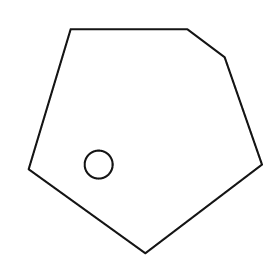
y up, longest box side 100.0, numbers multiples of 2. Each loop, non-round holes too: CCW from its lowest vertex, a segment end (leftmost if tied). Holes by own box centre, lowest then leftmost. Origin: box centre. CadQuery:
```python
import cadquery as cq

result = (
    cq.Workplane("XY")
    .moveTo(0.0, -48.0)
    .lineTo(50.0, -10.0)
    .lineTo(34.0, 36.0)
    .lineTo(18.0, 48.0)
    .lineTo(-32.0, 48.0)
    .lineTo(-50.0, -12.0)
    .close()
    .moveTo(-20.0, -10.0)
    .circle(6.0)
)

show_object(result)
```